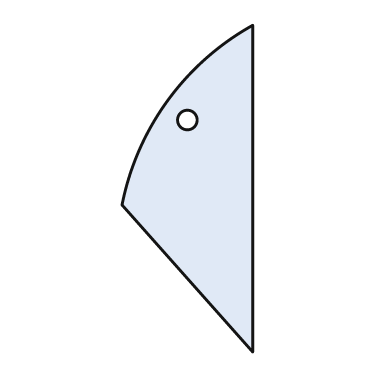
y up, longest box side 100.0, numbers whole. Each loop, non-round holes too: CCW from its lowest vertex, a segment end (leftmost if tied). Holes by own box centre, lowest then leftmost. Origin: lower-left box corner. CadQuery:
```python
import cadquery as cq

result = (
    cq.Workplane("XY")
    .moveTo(40.0, 0.0)
    .lineTo(40.0, 100.0)
    .threePointArc((14.0, 77.0), (0.0, 45.0))
    .close()
    .moveTo(20.0, 71.0)
    .circle(3.0)
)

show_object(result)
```